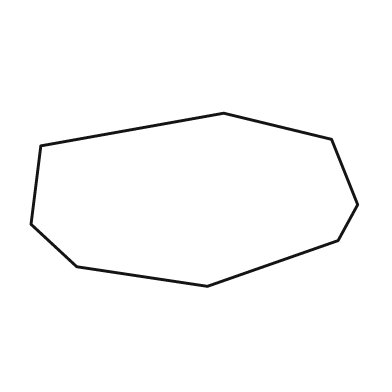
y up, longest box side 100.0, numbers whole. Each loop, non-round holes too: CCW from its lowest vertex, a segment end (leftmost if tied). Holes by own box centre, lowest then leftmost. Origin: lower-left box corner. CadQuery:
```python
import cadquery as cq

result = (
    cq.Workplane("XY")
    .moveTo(54.0, 0.0)
    .lineTo(94.0, 14.0)
    .lineTo(100.0, 25.0)
    .lineTo(92.0, 45.0)
    .lineTo(59.0, 53.0)
    .lineTo(3.0, 43.0)
    .lineTo(0.0, 19.0)
    .lineTo(14.0, 6.0)
    .close()
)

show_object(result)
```